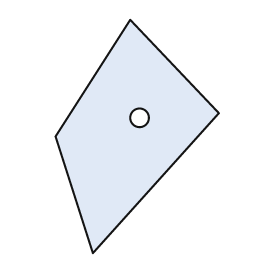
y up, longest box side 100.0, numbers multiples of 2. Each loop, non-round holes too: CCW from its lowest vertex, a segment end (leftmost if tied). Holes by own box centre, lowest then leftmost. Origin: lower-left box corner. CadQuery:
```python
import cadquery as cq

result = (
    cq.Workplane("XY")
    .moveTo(16.0, 0.0)
    .lineTo(70.0, 60.0)
    .lineTo(32.0, 100.0)
    .lineTo(0.0, 50.0)
    .close()
    .moveTo(36.0, 58.0)
    .circle(4.0)
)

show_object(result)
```